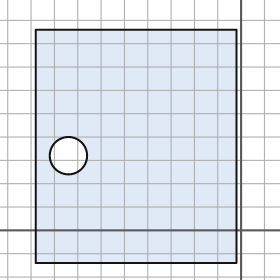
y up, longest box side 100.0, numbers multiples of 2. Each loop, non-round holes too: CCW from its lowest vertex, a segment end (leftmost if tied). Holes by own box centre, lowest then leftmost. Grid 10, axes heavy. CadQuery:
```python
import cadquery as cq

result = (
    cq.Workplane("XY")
    .moveTo(-88.0, -14.0)
    .lineTo(-2.0, -14.0)
    .lineTo(-2.0, 86.0)
    .lineTo(-88.0, 86.0)
    .close()
    .moveTo(-74.0, 32.0)
    .circle(8.0)
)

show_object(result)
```